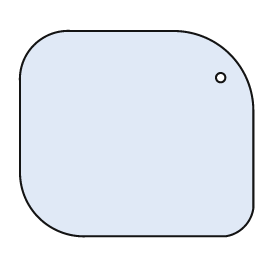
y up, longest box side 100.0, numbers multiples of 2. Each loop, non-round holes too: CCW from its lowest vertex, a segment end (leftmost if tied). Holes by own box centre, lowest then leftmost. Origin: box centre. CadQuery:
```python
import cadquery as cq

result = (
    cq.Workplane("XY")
    .moveTo(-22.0, -44.0)
    .lineTo(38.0, -44.0)
    .threePointArc((46.0, -40.0), (50.0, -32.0))
    .lineTo(50.0, 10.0)
    .threePointArc((40.0, 34.0), (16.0, 44.0))
    .lineTo(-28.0, 44.0)
    .threePointArc((-44.0, 38.0), (-50.0, 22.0))
    .lineTo(-50.0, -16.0)
    .threePointArc((-42.0, -36.0), (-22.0, -44.0))
    .close()
    .moveTo(36.0, 24.0)
    .circle(2.0)
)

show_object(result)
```